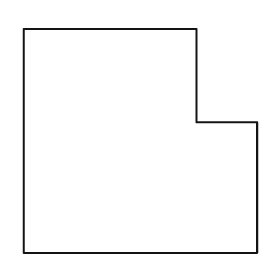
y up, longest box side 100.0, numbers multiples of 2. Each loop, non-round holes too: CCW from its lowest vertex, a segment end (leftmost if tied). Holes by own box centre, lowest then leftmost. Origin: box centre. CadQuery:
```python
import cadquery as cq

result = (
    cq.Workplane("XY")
    .moveTo(-50.0, -48.0)
    .lineTo(50.0, -48.0)
    .lineTo(50.0, 8.0)
    .lineTo(24.0, 8.0)
    .lineTo(24.0, 48.0)
    .lineTo(-50.0, 48.0)
    .close()
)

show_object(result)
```